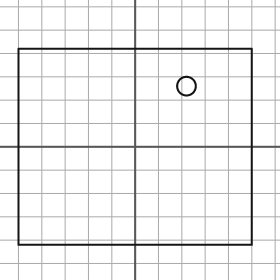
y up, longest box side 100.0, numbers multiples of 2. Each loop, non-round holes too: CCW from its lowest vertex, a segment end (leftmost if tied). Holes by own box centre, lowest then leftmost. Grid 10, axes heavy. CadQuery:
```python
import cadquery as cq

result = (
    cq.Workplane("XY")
    .moveTo(-50.0, -42.0)
    .lineTo(50.0, -42.0)
    .lineTo(50.0, 42.0)
    .lineTo(-50.0, 42.0)
    .close()
    .moveTo(22.0, 26.0)
    .circle(4.0)
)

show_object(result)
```